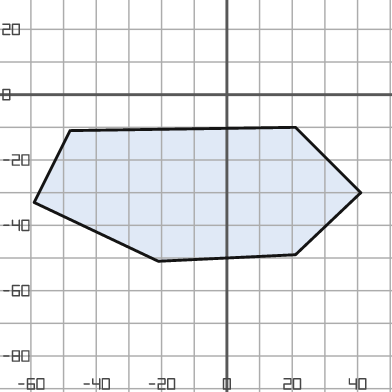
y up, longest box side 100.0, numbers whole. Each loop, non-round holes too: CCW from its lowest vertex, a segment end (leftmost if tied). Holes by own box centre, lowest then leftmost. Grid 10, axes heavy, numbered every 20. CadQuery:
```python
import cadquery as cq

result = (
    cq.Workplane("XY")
    .moveTo(-21.0, -51.0)
    .lineTo(21.0, -49.0)
    .lineTo(41.0, -30.0)
    .lineTo(21.0, -10.0)
    .lineTo(-48.0, -11.0)
    .lineTo(-59.0, -33.0)
    .close()
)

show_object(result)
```